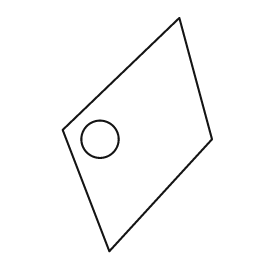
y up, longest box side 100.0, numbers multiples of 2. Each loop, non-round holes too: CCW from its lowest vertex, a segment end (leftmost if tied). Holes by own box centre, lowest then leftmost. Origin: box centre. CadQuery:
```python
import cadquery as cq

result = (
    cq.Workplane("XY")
    .moveTo(-12.0, -50.0)
    .lineTo(32.0, -2.0)
    .lineTo(18.0, 50.0)
    .lineTo(-32.0, 2.0)
    .close()
    .moveTo(-16.0, -2.0)
    .circle(8.0)
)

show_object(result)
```